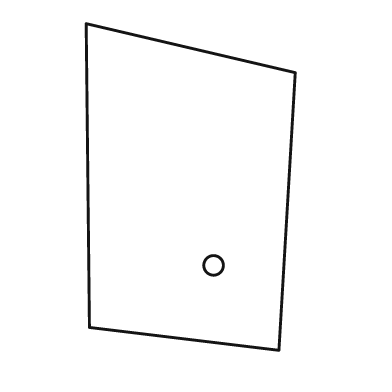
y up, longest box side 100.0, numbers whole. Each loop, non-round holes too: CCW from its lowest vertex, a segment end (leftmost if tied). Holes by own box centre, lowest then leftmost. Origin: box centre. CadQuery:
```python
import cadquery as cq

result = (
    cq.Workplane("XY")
    .moveTo(27.0, -50.0)
    .lineTo(32.0, 35.0)
    .lineTo(-32.0, 50.0)
    .lineTo(-31.0, -43.0)
    .close()
    .moveTo(7.0, -24.0)
    .circle(3.0)
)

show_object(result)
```